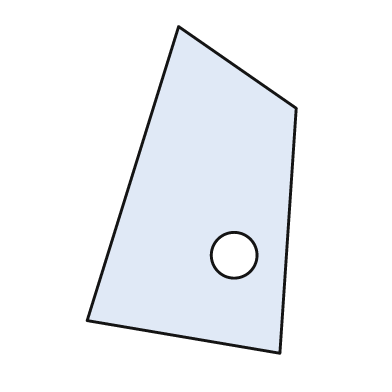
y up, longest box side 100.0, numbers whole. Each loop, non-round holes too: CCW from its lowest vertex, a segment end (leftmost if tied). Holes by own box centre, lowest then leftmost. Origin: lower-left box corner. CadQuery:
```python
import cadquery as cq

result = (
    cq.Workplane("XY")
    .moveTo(59.0, 0.0)
    .lineTo(64.0, 75.0)
    .lineTo(28.0, 100.0)
    .lineTo(0.0, 10.0)
    .close()
    .moveTo(45.0, 30.0)
    .circle(7.0)
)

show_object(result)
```